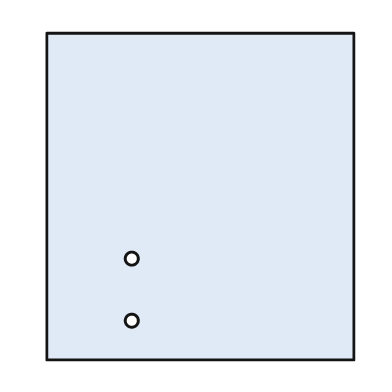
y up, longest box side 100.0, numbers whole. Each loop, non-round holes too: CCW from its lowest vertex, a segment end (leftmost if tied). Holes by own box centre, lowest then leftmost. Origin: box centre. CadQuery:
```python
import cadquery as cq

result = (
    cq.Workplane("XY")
    .moveTo(-47.0, -50.0)
    .lineTo(47.0, -50.0)
    .lineTo(47.0, 50.0)
    .lineTo(-47.0, 50.0)
    .close()
    .moveTo(-21.0, -38.0)
    .circle(2.0)
    .moveTo(-21.0, -19.0)
    .circle(2.0)
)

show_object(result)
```